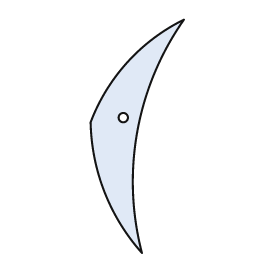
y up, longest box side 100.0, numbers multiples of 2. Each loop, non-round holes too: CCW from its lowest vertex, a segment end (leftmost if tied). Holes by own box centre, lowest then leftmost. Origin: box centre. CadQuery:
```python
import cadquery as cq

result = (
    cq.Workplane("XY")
    .moveTo(2.0, -50.0)
    .threePointArc((0.0, 2.0), (20.0, 50.0))
    .threePointArc((-4.0, 32.0), (-20.0, 6.0))
    .threePointArc((-14.0, -24.0), (2.0, -50.0))
    .close()
    .moveTo(-6.0, 8.0)
    .circle(2.0)
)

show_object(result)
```